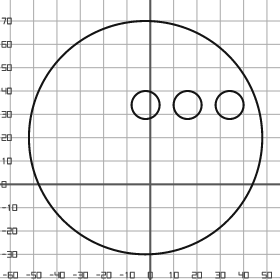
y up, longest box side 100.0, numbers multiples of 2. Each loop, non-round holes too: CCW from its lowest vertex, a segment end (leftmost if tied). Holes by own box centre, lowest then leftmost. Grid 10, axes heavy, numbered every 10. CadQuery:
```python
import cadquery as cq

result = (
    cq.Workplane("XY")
    .moveTo(-2.0, 20.0)
    .circle(50.0)
    .moveTo(-2.0, 34.0)
    .circle(6.0)
    .moveTo(16.0, 34.0)
    .circle(6.0)
    .moveTo(34.0, 34.0)
    .circle(6.0)
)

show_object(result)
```